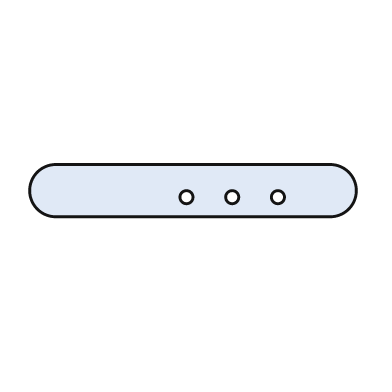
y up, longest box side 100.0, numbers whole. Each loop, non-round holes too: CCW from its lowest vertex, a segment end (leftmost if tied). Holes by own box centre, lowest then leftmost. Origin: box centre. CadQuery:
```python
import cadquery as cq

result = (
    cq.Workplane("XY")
    .moveTo(-42.0, -8.0)
    .lineTo(42.0, -8.0)
    .threePointArc((50.0, 0.0), (42.0, 8.0))
    .lineTo(-42.0, 8.0)
    .threePointArc((-50.0, 0.0), (-42.0, -8.0))
    .close()
    .moveTo(-2.0, -2.0)
    .circle(2.0)
    .moveTo(12.0, -2.0)
    .circle(2.0)
    .moveTo(26.0, -2.0)
    .circle(2.0)
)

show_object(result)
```